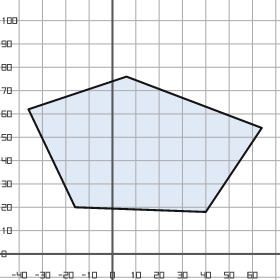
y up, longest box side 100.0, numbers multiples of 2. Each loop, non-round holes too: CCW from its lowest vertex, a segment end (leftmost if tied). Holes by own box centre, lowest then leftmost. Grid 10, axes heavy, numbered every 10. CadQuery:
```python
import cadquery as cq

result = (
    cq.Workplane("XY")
    .moveTo(40.0, 18.0)
    .lineTo(64.0, 54.0)
    .lineTo(6.0, 76.0)
    .lineTo(-36.0, 62.0)
    .lineTo(-16.0, 20.0)
    .close()
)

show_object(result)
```